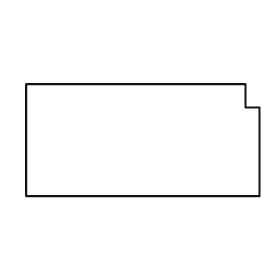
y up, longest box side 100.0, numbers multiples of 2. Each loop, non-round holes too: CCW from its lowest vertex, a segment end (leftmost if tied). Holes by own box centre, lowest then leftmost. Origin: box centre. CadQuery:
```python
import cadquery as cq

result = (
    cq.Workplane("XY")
    .moveTo(-50.0, -24.0)
    .lineTo(50.0, -24.0)
    .lineTo(50.0, 14.0)
    .lineTo(44.0, 14.0)
    .lineTo(44.0, 24.0)
    .lineTo(-50.0, 24.0)
    .close()
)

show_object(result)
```